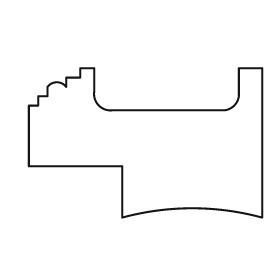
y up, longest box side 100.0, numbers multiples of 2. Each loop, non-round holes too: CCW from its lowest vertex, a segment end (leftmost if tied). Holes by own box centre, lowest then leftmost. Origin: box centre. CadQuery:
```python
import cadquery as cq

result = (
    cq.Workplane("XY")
    .moveTo(-10.0, -32.0)
    .threePointArc((20.0, -28.0), (50.0, -32.0))
    .lineTo(50.0, 32.0)
    .lineTo(40.0, 32.0)
    .lineTo(40.0, 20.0)
    .threePointArc((38.0, 16.0), (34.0, 14.0))
    .lineTo(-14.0, 14.0)
    .threePointArc((-20.0, 16.0), (-22.0, 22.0))
    .lineTo(-22.0, 32.0)
    .lineTo(-28.0, 32.0)
    .lineTo(-28.0, 28.0)
    .lineTo(-34.0, 28.0)
    .lineTo(-34.0, 24.0)
    .threePointArc((-38.0, 26.0), (-42.0, 24.0))
    .lineTo(-42.0, 20.0)
    .lineTo(-46.0, 20.0)
    .lineTo(-46.0, 16.0)
    .lineTo(-50.0, 16.0)
    .lineTo(-50.0, -10.0)
    .lineTo(-10.0, -10.0)
    .close()
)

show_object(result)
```